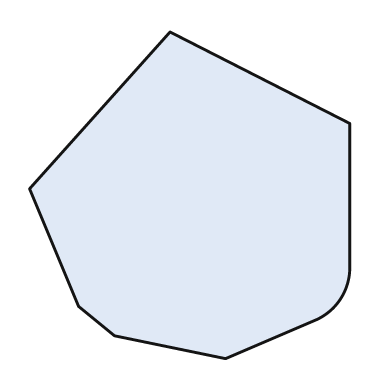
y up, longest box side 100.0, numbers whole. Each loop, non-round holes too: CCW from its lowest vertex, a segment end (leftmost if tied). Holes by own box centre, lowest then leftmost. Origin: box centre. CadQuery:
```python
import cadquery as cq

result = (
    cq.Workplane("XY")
    .moveTo(11.0, -50.0)
    .lineTo(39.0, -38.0)
    .threePointArc((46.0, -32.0), (49.0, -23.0))
    .lineTo(49.0, 22.0)
    .lineTo(-6.0, 50.0)
    .lineTo(-49.0, 2.0)
    .lineTo(-34.0, -34.0)
    .lineTo(-23.0, -43.0)
    .close()
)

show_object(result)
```